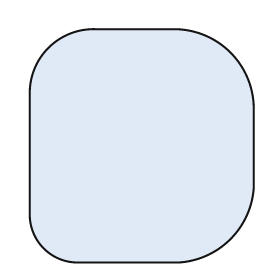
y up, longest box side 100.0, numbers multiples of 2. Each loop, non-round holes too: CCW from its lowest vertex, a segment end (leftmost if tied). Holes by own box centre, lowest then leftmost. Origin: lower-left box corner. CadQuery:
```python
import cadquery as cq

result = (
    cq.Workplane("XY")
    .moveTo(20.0, 0.0)
    .lineTo(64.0, 0.0)
    .threePointArc((86.0, 10.0), (96.0, 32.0))
    .lineTo(96.0, 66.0)
    .threePointArc((86.0, 90.0), (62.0, 100.0))
    .lineTo(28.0, 100.0)
    .threePointArc((8.0, 92.0), (0.0, 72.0))
    .lineTo(0.0, 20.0)
    .threePointArc((6.0, 6.0), (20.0, 0.0))
    .close()
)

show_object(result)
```